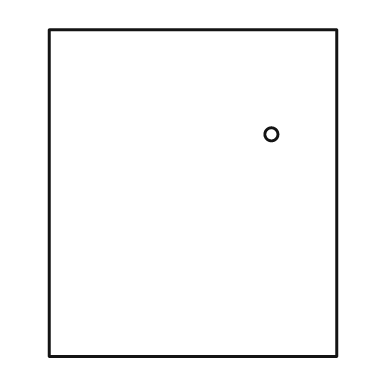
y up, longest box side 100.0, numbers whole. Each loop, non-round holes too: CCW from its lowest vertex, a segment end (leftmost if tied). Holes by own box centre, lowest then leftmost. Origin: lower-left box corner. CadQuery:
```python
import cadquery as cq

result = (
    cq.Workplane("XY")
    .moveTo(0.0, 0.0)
    .lineTo(88.0, 0.0)
    .lineTo(88.0, 100.0)
    .lineTo(0.0, 100.0)
    .close()
    .moveTo(68.0, 68.0)
    .circle(2.0)
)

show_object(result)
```